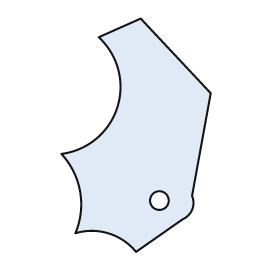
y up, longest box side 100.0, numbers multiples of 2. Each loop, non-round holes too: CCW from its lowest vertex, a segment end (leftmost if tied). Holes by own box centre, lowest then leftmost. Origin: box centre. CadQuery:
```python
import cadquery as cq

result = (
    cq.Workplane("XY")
    .moveTo(0.0, -50.0)
    .lineTo(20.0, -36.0)
    .threePointArc((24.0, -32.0), (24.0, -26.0))
    .lineTo(32.0, 18.0)
    .lineTo(2.0, 50.0)
    .lineTo(-16.0, 42.0)
    .threePointArc((-8.0, 12.0), (-32.0, -8.0))
    .threePointArc((-24.0, -24.0), (-26.0, -42.0))
    .threePointArc((-12.0, -42.0), (0.0, -50.0))
    .close()
    .moveTo(10.0, -28.0)
    .circle(4.0)
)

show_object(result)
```